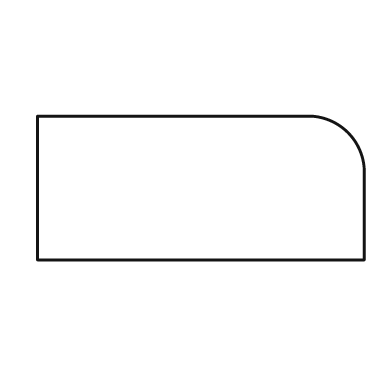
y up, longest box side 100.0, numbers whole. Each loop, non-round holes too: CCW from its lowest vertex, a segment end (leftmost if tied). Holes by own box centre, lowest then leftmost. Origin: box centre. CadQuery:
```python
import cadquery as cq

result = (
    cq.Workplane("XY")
    .moveTo(-50.0, -22.0)
    .lineTo(50.0, -22.0)
    .lineTo(50.0, 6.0)
    .threePointArc((45.0, 17.0), (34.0, 22.0))
    .lineTo(-50.0, 22.0)
    .close()
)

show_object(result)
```